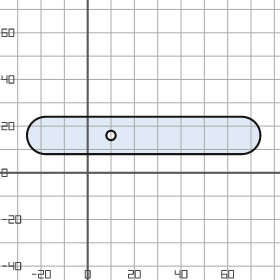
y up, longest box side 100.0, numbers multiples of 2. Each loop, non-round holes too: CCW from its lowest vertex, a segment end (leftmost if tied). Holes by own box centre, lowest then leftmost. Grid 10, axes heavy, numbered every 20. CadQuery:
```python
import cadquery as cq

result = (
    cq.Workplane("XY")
    .moveTo(-18.0, 8.0)
    .lineTo(66.0, 8.0)
    .threePointArc((74.0, 16.0), (66.0, 24.0))
    .lineTo(-18.0, 24.0)
    .threePointArc((-26.0, 16.0), (-18.0, 8.0))
    .close()
    .moveTo(10.0, 16.0)
    .circle(2.0)
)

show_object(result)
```